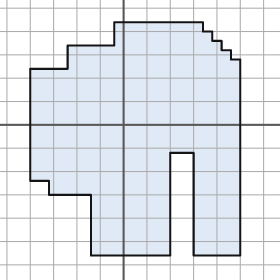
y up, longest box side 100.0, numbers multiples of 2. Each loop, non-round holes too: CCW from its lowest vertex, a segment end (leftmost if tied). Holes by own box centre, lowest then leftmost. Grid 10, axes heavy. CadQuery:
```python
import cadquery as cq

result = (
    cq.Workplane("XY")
    .moveTo(-14.0, -56.0)
    .lineTo(20.0, -56.0)
    .lineTo(20.0, -12.0)
    .lineTo(30.0, -12.0)
    .lineTo(30.0, -56.0)
    .lineTo(50.0, -56.0)
    .lineTo(50.0, 28.0)
    .lineTo(46.0, 28.0)
    .lineTo(46.0, 32.0)
    .lineTo(42.0, 32.0)
    .lineTo(42.0, 36.0)
    .lineTo(38.0, 36.0)
    .lineTo(38.0, 40.0)
    .lineTo(34.0, 40.0)
    .lineTo(34.0, 44.0)
    .lineTo(-4.0, 44.0)
    .lineTo(-4.0, 34.0)
    .lineTo(-24.0, 34.0)
    .lineTo(-24.0, 24.0)
    .lineTo(-40.0, 24.0)
    .lineTo(-40.0, -24.0)
    .lineTo(-32.0, -24.0)
    .lineTo(-32.0, -30.0)
    .lineTo(-14.0, -30.0)
    .close()
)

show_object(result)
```